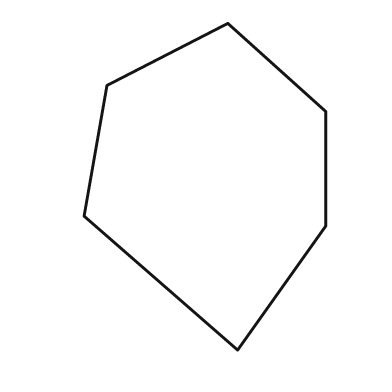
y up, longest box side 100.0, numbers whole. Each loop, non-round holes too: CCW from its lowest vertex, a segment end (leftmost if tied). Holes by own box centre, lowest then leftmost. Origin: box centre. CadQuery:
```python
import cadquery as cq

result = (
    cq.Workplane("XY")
    .moveTo(10.0, -50.0)
    .lineTo(37.0, -12.0)
    .lineTo(37.0, 23.0)
    .lineTo(7.0, 50.0)
    .lineTo(-30.0, 31.0)
    .lineTo(-37.0, -9.0)
    .close()
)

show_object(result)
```